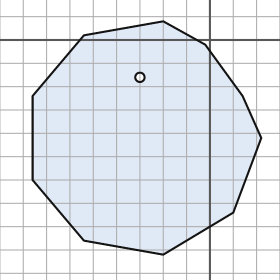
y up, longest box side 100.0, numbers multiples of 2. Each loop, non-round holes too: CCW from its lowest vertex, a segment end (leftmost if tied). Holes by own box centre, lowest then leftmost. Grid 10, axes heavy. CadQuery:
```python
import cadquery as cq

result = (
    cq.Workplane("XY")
    .moveTo(-20.0, -92.0)
    .lineTo(10.0, -74.0)
    .lineTo(22.0, -42.0)
    .lineTo(14.0, -24.0)
    .lineTo(-2.0, -2.0)
    .lineTo(-20.0, 8.0)
    .lineTo(-54.0, 2.0)
    .lineTo(-76.0, -24.0)
    .lineTo(-76.0, -60.0)
    .lineTo(-54.0, -86.0)
    .close()
    .moveTo(-30.0, -16.0)
    .circle(2.0)
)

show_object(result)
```